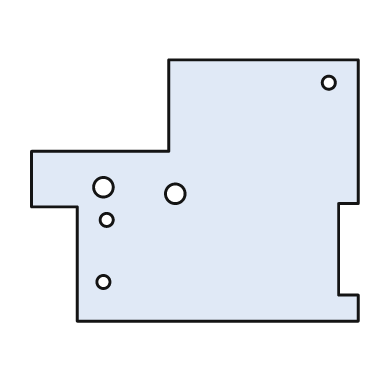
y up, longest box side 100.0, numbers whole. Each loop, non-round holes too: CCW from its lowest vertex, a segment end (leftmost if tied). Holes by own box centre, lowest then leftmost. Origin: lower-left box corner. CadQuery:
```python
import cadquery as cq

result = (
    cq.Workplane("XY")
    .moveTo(14.0, 0.0)
    .lineTo(100.0, 0.0)
    .lineTo(100.0, 8.0)
    .lineTo(94.0, 8.0)
    .lineTo(94.0, 36.0)
    .lineTo(100.0, 36.0)
    .lineTo(100.0, 80.0)
    .lineTo(42.0, 80.0)
    .lineTo(42.0, 52.0)
    .lineTo(0.0, 52.0)
    .lineTo(0.0, 35.0)
    .lineTo(14.0, 35.0)
    .close()
    .moveTo(22.0, 12.0)
    .circle(2.0)
    .moveTo(23.0, 31.0)
    .circle(2.0)
    .moveTo(44.0, 39.0)
    .circle(3.0)
    .moveTo(22.0, 41.0)
    .circle(3.0)
    .moveTo(91.0, 73.0)
    .circle(2.0)
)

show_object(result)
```